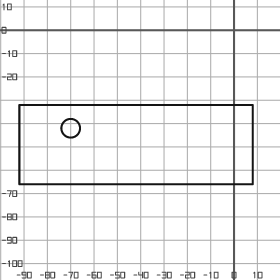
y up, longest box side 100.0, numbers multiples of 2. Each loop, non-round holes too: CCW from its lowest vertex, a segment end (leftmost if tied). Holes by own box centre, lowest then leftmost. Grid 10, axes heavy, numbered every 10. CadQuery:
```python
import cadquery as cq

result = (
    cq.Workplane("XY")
    .moveTo(-92.0, -66.0)
    .lineTo(8.0, -66.0)
    .lineTo(8.0, -32.0)
    .lineTo(-92.0, -32.0)
    .close()
    .moveTo(-70.0, -42.0)
    .circle(4.0)
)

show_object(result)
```